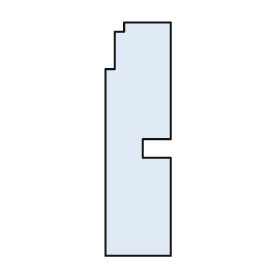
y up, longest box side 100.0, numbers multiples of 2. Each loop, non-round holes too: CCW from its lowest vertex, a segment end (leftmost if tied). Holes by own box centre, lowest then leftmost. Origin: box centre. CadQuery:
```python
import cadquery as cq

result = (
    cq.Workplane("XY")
    .moveTo(-14.0, -50.0)
    .lineTo(14.0, -50.0)
    .lineTo(14.0, -8.0)
    .lineTo(2.0, -8.0)
    .lineTo(2.0, 0.0)
    .lineTo(14.0, 0.0)
    .lineTo(14.0, 50.0)
    .lineTo(-6.0, 50.0)
    .lineTo(-6.0, 46.0)
    .lineTo(-10.0, 46.0)
    .lineTo(-10.0, 30.0)
    .lineTo(-14.0, 30.0)
    .close()
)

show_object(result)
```